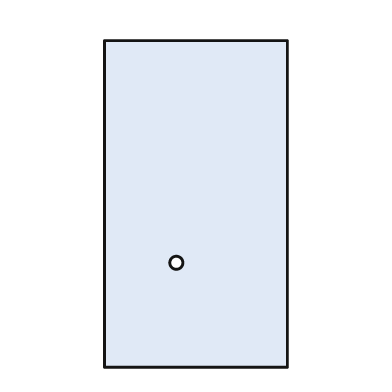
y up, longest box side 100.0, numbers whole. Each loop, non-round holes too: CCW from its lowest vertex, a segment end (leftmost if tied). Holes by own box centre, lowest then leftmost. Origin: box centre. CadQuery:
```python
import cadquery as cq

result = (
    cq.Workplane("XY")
    .moveTo(-28.0, -50.0)
    .lineTo(28.0, -50.0)
    .lineTo(28.0, 50.0)
    .lineTo(-28.0, 50.0)
    .close()
    .moveTo(-6.0, -18.0)
    .circle(2.0)
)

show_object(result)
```